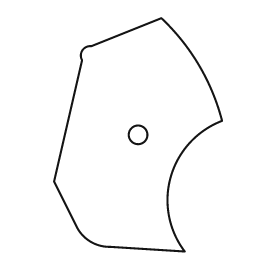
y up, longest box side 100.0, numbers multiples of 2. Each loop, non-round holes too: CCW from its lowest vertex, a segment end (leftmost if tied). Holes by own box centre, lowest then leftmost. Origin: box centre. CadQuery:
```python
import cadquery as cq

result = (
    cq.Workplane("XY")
    .moveTo(20.0, -50.0)
    .threePointArc((14.0, -18.0), (36.0, 6.0))
    .threePointArc((26.0, 30.0), (10.0, 50.0))
    .lineTo(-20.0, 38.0)
    .threePointArc((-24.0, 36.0), (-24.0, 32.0))
    .lineTo(-36.0, -20.0)
    .lineTo(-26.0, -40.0)
    .threePointArc((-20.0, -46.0), (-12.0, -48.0))
    .close()
    .moveTo(0.0, 0.0)
    .circle(4.0)
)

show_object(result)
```